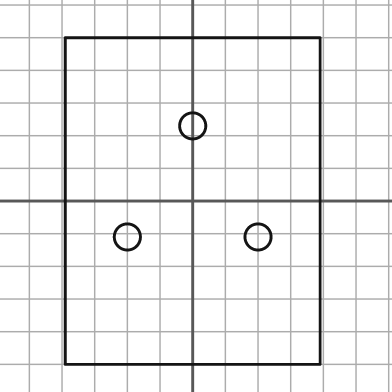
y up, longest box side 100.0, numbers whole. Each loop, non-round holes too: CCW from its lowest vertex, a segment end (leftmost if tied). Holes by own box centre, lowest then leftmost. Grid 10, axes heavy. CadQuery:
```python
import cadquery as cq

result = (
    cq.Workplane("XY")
    .moveTo(-39.0, -50.0)
    .lineTo(39.0, -50.0)
    .lineTo(39.0, 50.0)
    .lineTo(-39.0, 50.0)
    .close()
    .moveTo(-20.0, -11.0)
    .circle(4.0)
    .moveTo(20.0, -11.0)
    .circle(4.0)
    .moveTo(0.0, 23.0)
    .circle(4.0)
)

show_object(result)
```